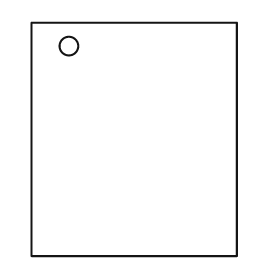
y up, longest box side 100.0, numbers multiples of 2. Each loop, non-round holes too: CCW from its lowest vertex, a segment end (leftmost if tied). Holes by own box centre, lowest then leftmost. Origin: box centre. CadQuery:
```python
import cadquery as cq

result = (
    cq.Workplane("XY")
    .moveTo(-44.0, -50.0)
    .lineTo(44.0, -50.0)
    .lineTo(44.0, 50.0)
    .lineTo(-44.0, 50.0)
    .close()
    .moveTo(-28.0, 40.0)
    .circle(4.0)
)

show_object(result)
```